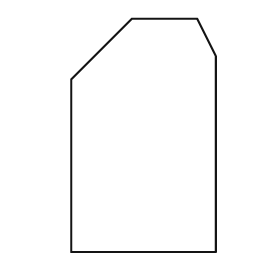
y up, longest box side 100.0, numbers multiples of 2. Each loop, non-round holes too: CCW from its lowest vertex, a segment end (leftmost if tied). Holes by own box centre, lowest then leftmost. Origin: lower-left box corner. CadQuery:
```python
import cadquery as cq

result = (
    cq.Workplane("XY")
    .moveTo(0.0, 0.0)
    .lineTo(62.0, 0.0)
    .lineTo(62.0, 84.0)
    .lineTo(54.0, 100.0)
    .lineTo(26.0, 100.0)
    .lineTo(0.0, 74.0)
    .close()
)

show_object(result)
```